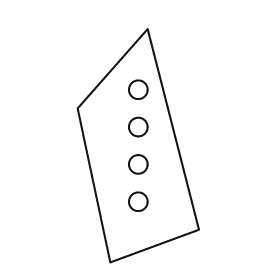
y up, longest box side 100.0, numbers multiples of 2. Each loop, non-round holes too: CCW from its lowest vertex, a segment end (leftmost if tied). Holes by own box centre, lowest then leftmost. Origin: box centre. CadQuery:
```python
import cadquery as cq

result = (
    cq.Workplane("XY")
    .moveTo(-12.0, -50.0)
    .lineTo(26.0, -36.0)
    .lineTo(4.0, 50.0)
    .lineTo(-26.0, 16.0)
    .close()
    .moveTo(0.0, -24.0)
    .circle(4.0)
    .moveTo(0.0, -8.0)
    .circle(4.0)
    .moveTo(0.0, 8.0)
    .circle(4.0)
    .moveTo(0.0, 24.0)
    .circle(4.0)
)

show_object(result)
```